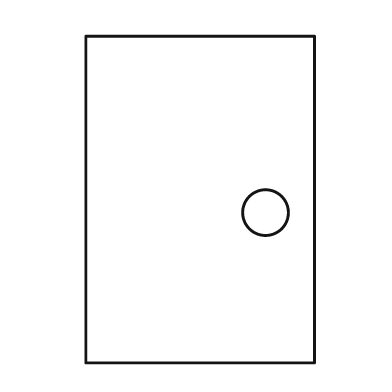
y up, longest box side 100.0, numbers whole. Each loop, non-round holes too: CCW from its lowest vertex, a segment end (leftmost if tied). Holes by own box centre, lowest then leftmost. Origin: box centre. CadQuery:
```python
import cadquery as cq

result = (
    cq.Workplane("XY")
    .moveTo(-35.0, -50.0)
    .lineTo(35.0, -50.0)
    .lineTo(35.0, 50.0)
    .lineTo(-35.0, 50.0)
    .close()
    .moveTo(20.0, -4.0)
    .circle(7.0)
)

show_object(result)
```